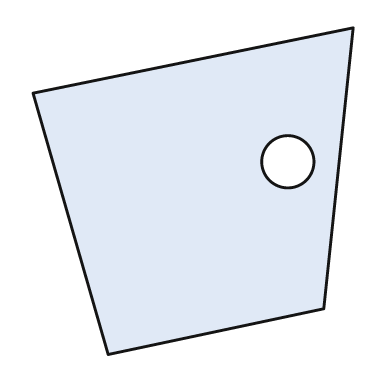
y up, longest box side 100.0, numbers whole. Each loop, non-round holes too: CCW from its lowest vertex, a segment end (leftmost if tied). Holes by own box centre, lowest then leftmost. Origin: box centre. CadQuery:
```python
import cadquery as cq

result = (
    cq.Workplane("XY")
    .moveTo(-26.0, -50.0)
    .lineTo(40.0, -36.0)
    .lineTo(49.0, 50.0)
    .lineTo(-49.0, 30.0)
    .close()
    .moveTo(29.0, 9.0)
    .circle(8.0)
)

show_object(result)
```